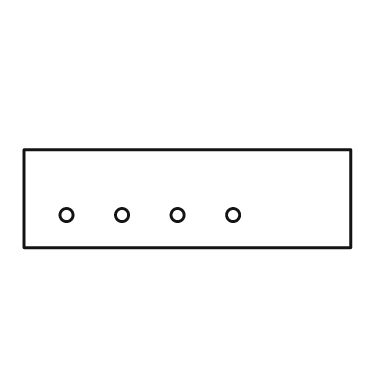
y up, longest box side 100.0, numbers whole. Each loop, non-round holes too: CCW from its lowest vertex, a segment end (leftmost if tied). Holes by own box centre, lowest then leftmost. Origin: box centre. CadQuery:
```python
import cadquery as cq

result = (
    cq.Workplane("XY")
    .moveTo(-50.0, -15.0)
    .lineTo(50.0, -15.0)
    .lineTo(50.0, 15.0)
    .lineTo(-50.0, 15.0)
    .close()
    .moveTo(-37.0, -5.0)
    .circle(2.0)
    .moveTo(-20.0, -5.0)
    .circle(2.0)
    .moveTo(-3.0, -5.0)
    .circle(2.0)
    .moveTo(14.0, -5.0)
    .circle(2.0)
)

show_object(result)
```